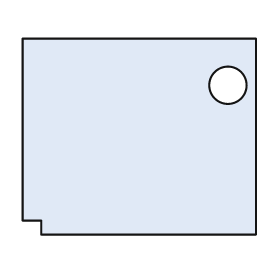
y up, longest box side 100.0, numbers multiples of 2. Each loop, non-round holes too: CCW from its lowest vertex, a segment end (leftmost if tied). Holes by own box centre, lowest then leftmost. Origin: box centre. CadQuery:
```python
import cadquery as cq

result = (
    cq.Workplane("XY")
    .moveTo(-42.0, -42.0)
    .lineTo(50.0, -42.0)
    .lineTo(50.0, 42.0)
    .lineTo(-50.0, 42.0)
    .lineTo(-50.0, -36.0)
    .lineTo(-42.0, -36.0)
    .close()
    .moveTo(38.0, 22.0)
    .circle(8.0)
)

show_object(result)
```